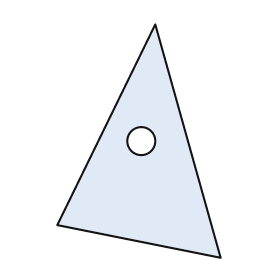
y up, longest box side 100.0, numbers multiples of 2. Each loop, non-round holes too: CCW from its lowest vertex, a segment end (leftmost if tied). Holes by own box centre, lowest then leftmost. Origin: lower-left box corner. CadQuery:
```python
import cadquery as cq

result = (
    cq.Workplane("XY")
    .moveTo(70.0, 0.0)
    .lineTo(42.0, 100.0)
    .lineTo(0.0, 14.0)
    .close()
    .moveTo(36.0, 50.0)
    .circle(6.0)
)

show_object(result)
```